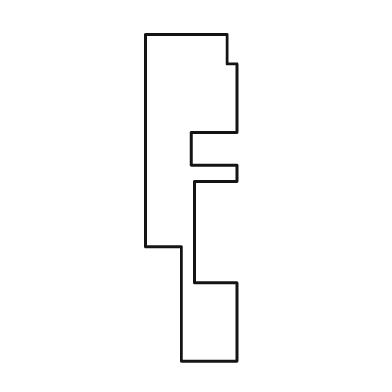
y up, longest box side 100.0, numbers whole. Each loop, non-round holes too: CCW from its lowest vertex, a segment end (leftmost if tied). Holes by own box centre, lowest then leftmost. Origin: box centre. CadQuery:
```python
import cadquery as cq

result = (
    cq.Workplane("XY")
    .moveTo(-3.0, -50.0)
    .lineTo(14.0, -50.0)
    .lineTo(14.0, -26.0)
    .lineTo(1.0, -26.0)
    .lineTo(1.0, 5.0)
    .lineTo(14.0, 5.0)
    .lineTo(14.0, 10.0)
    .lineTo(0.0, 10.0)
    .lineTo(0.0, 20.0)
    .lineTo(14.0, 20.0)
    .lineTo(14.0, 41.0)
    .lineTo(11.0, 41.0)
    .lineTo(11.0, 50.0)
    .lineTo(-14.0, 50.0)
    .lineTo(-14.0, -15.0)
    .lineTo(-3.0, -15.0)
    .close()
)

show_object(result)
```